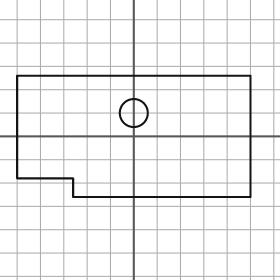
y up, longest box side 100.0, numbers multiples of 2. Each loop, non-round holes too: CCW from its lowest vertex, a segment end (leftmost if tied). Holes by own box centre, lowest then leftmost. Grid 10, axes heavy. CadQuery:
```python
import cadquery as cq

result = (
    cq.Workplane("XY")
    .moveTo(-26.0, -26.0)
    .lineTo(50.0, -26.0)
    .lineTo(50.0, 26.0)
    .lineTo(-50.0, 26.0)
    .lineTo(-50.0, -18.0)
    .lineTo(-26.0, -18.0)
    .close()
    .moveTo(0.0, 10.0)
    .circle(6.0)
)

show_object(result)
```